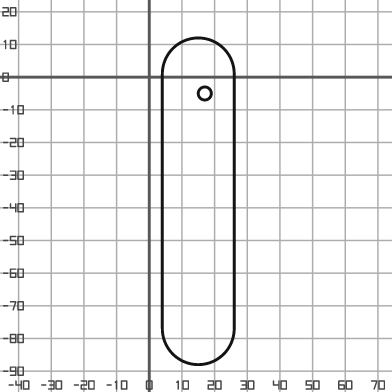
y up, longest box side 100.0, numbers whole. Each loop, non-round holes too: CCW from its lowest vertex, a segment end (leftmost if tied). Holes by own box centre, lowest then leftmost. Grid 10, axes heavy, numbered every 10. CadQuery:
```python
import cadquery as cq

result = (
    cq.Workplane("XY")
    .moveTo(4.0, -77.0)
    .threePointArc((15.0, -88.0), (26.0, -77.0))
    .lineTo(26.0, 1.0)
    .threePointArc((15.0, 12.0), (4.0, 1.0))
    .close()
    .moveTo(17.0, -5.0)
    .circle(2.0)
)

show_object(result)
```